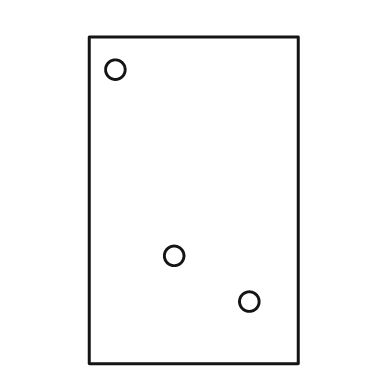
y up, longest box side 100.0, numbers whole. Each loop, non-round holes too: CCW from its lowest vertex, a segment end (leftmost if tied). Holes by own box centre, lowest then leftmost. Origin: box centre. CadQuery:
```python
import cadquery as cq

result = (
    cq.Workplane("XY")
    .moveTo(-32.0, -50.0)
    .lineTo(32.0, -50.0)
    .lineTo(32.0, 50.0)
    .lineTo(-32.0, 50.0)
    .close()
    .moveTo(17.0, -31.0)
    .circle(3.0)
    .moveTo(-6.0, -17.0)
    .circle(3.0)
    .moveTo(-24.0, 40.0)
    .circle(3.0)
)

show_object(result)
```